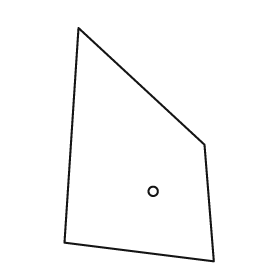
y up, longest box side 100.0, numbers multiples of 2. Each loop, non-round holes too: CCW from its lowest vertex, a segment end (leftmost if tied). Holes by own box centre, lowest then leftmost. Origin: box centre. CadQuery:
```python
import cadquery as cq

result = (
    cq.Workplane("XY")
    .moveTo(32.0, -50.0)
    .lineTo(28.0, 0.0)
    .lineTo(-26.0, 50.0)
    .lineTo(-32.0, -42.0)
    .close()
    .moveTo(6.0, -20.0)
    .circle(2.0)
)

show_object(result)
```